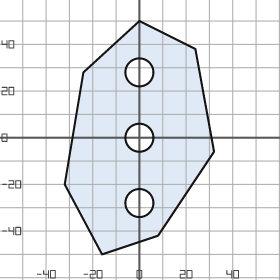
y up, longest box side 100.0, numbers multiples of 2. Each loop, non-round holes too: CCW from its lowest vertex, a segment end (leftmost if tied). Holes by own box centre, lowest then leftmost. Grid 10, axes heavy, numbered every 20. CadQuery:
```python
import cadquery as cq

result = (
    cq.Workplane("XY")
    .moveTo(-16.0, -50.0)
    .lineTo(8.0, -42.0)
    .lineTo(32.0, -6.0)
    .lineTo(24.0, 38.0)
    .lineTo(0.0, 50.0)
    .lineTo(-24.0, 28.0)
    .lineTo(-32.0, -20.0)
    .close()
    .moveTo(0.0, -28.0)
    .circle(6.0)
    .moveTo(0.0, 0.0)
    .circle(6.0)
    .moveTo(0.0, 28.0)
    .circle(6.0)
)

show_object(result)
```